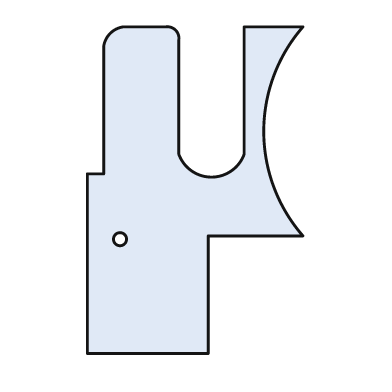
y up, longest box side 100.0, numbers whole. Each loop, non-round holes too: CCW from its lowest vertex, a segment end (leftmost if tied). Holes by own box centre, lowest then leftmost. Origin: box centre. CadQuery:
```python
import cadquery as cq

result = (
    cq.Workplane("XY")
    .moveTo(-33.0, -50.0)
    .lineTo(4.0, -50.0)
    .lineTo(4.0, -14.0)
    .lineTo(33.0, -14.0)
    .threePointArc((21.0, 18.0), (33.0, 50.0))
    .lineTo(15.0, 50.0)
    .lineTo(15.0, 11.0)
    .threePointArc((5.0, 4.0), (-5.0, 11.0))
    .lineTo(-5.0, 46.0)
    .threePointArc((-6.0, 49.0), (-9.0, 50.0))
    .lineTo(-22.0, 50.0)
    .threePointArc((-26.0, 48.0), (-28.0, 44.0))
    .lineTo(-28.0, 5.0)
    .lineTo(-33.0, 5.0)
    .close()
    .moveTo(-23.0, -15.0)
    .circle(2.0)
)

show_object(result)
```